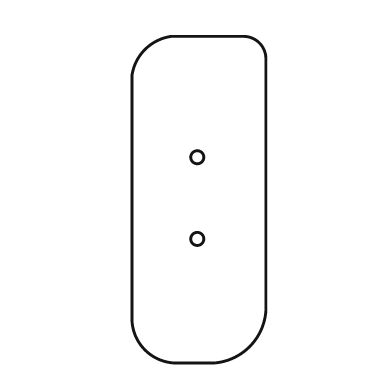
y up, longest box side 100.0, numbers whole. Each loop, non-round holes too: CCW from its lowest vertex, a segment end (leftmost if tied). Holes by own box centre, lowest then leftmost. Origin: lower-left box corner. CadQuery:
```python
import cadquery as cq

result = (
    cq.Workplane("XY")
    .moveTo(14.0, 0.0)
    .lineTo(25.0, 0.0)
    .threePointArc((36.0, 5.0), (41.0, 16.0))
    .lineTo(41.0, 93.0)
    .threePointArc((39.0, 98.0), (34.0, 100.0))
    .lineTo(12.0, 100.0)
    .threePointArc((4.0, 96.0), (0.0, 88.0))
    .lineTo(0.0, 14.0)
    .threePointArc((4.0, 4.0), (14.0, 0.0))
    .close()
    .moveTo(20.0, 38.0)
    .circle(2.0)
    .moveTo(20.0, 63.0)
    .circle(2.0)
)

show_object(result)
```